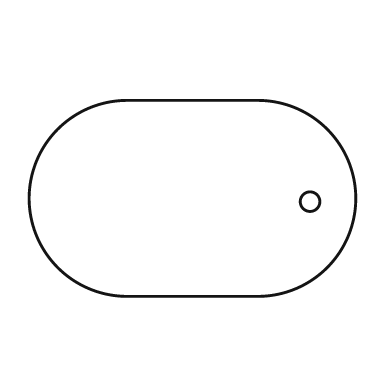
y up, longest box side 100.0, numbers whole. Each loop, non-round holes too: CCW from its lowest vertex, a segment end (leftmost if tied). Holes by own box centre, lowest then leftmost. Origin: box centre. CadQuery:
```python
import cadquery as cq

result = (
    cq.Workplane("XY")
    .moveTo(-20.0, -30.0)
    .lineTo(20.0, -30.0)
    .threePointArc((50.0, 0.0), (20.0, 30.0))
    .lineTo(-20.0, 30.0)
    .threePointArc((-50.0, 0.0), (-20.0, -30.0))
    .close()
    .moveTo(36.0, -1.0)
    .circle(3.0)
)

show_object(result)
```